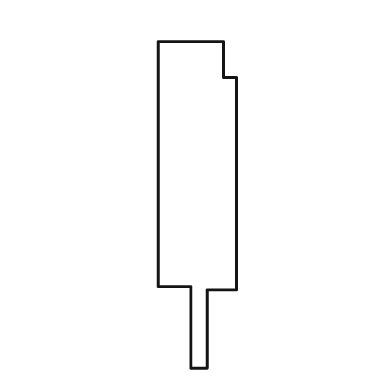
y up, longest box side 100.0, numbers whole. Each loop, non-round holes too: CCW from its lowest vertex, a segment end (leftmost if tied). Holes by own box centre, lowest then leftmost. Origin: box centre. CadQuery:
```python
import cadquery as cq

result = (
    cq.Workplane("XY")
    .moveTo(-2.0, -50.0)
    .lineTo(3.0, -50.0)
    .lineTo(3.0, -26.0)
    .lineTo(12.0, -26.0)
    .lineTo(12.0, 39.0)
    .lineTo(8.0, 39.0)
    .lineTo(8.0, 50.0)
    .lineTo(-12.0, 50.0)
    .lineTo(-12.0, -25.0)
    .lineTo(-2.0, -25.0)
    .close()
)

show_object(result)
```